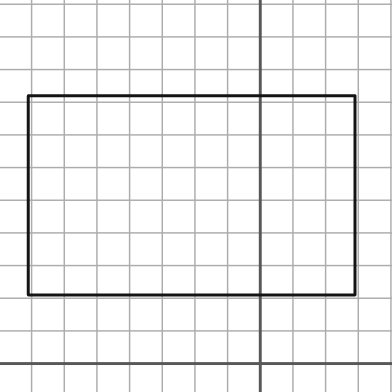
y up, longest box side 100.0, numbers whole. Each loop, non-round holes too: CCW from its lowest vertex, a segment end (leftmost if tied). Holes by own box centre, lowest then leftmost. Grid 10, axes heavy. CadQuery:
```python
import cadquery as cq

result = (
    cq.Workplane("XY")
    .moveTo(-71.0, 21.0)
    .lineTo(29.0, 21.0)
    .lineTo(29.0, 82.0)
    .lineTo(-71.0, 82.0)
    .close()
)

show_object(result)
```